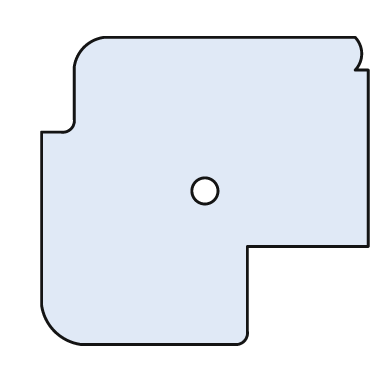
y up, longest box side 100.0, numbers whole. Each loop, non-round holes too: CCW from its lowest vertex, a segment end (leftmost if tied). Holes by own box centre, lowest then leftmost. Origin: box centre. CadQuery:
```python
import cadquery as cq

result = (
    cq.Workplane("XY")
    .moveTo(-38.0, -47.0)
    .lineTo(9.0, -47.0)
    .threePointArc((12.0, -46.0), (13.0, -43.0))
    .lineTo(13.0, -17.0)
    .lineTo(50.0, -17.0)
    .lineTo(50.0, 37.0)
    .lineTo(46.0, 37.0)
    .threePointArc((48.0, 42.0), (46.0, 47.0))
    .lineTo(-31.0, 47.0)
    .threePointArc((-37.0, 44.0), (-40.0, 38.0))
    .lineTo(-40.0, 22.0)
    .threePointArc((-41.0, 19.0), (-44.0, 18.0))
    .lineTo(-50.0, 18.0)
    .lineTo(-50.0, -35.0)
    .threePointArc((-46.0, -43.0), (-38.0, -47.0))
    .close()
    .moveTo(0.0, 0.0)
    .circle(4.0)
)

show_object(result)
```